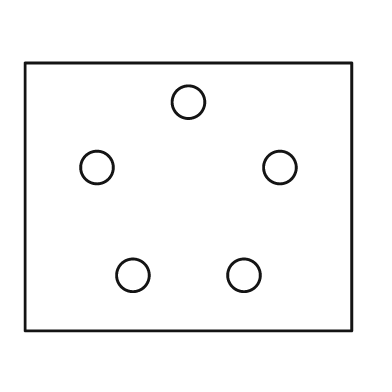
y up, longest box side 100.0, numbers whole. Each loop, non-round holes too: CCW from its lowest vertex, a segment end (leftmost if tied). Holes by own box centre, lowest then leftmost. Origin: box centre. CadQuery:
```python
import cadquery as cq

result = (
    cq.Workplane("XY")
    .moveTo(-50.0, -41.0)
    .lineTo(50.0, -41.0)
    .lineTo(50.0, 41.0)
    .lineTo(-50.0, 41.0)
    .close()
    .moveTo(-17.0, -24.0)
    .circle(5.0)
    .moveTo(17.0, -24.0)
    .circle(5.0)
    .moveTo(-28.0, 9.0)
    .circle(5.0)
    .moveTo(28.0, 9.0)
    .circle(5.0)
    .moveTo(0.0, 29.0)
    .circle(5.0)
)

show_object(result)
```